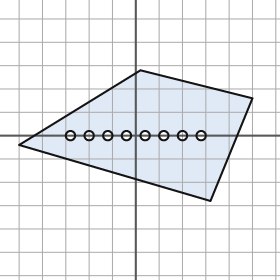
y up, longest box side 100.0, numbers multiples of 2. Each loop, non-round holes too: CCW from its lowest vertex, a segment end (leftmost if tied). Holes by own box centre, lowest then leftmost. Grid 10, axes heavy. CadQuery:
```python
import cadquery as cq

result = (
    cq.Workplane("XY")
    .moveTo(32.0, -28.0)
    .lineTo(50.0, 16.0)
    .lineTo(2.0, 28.0)
    .lineTo(-50.0, -4.0)
    .close()
    .moveTo(-28.0, 0.0)
    .circle(2.0)
    .moveTo(-20.0, 0.0)
    .circle(2.0)
    .moveTo(-12.0, 0.0)
    .circle(2.0)
    .moveTo(-4.0, 0.0)
    .circle(2.0)
    .moveTo(4.0, 0.0)
    .circle(2.0)
    .moveTo(12.0, 0.0)
    .circle(2.0)
    .moveTo(20.0, 0.0)
    .circle(2.0)
    .moveTo(28.0, 0.0)
    .circle(2.0)
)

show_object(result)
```